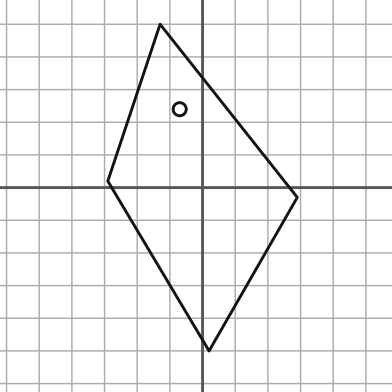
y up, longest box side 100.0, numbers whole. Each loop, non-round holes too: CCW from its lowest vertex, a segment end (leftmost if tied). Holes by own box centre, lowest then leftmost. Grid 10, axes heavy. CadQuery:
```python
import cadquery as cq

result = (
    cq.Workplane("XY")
    .moveTo(2.0, -50.0)
    .lineTo(29.0, -3.0)
    .lineTo(-13.0, 50.0)
    .lineTo(-29.0, 2.0)
    .close()
    .moveTo(-7.0, 24.0)
    .circle(2.0)
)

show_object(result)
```